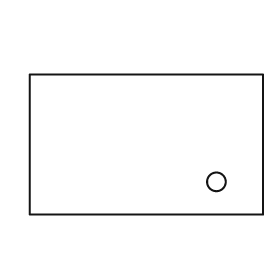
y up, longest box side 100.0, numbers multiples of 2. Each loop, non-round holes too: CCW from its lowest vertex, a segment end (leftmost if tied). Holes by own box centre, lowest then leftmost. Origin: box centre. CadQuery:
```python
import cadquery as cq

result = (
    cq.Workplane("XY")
    .moveTo(-50.0, -30.0)
    .lineTo(50.0, -30.0)
    .lineTo(50.0, 30.0)
    .lineTo(-50.0, 30.0)
    .close()
    .moveTo(30.0, -16.0)
    .circle(4.0)
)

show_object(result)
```